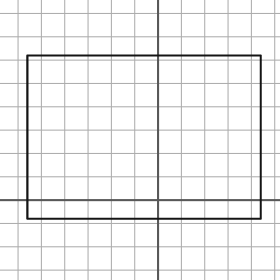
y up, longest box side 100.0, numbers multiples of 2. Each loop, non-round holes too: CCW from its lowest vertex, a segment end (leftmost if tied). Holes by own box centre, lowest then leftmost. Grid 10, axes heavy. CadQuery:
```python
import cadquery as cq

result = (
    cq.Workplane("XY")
    .moveTo(-56.0, -8.0)
    .lineTo(44.0, -8.0)
    .lineTo(44.0, 62.0)
    .lineTo(-56.0, 62.0)
    .close()
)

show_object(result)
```